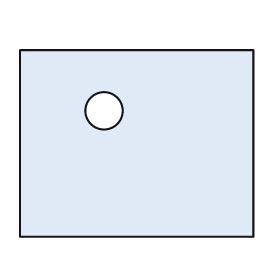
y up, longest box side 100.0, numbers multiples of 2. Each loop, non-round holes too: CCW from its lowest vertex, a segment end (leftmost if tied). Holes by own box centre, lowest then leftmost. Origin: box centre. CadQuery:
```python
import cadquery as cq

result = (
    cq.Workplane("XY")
    .moveTo(-50.0, -40.0)
    .lineTo(50.0, -40.0)
    .lineTo(50.0, 40.0)
    .lineTo(-50.0, 40.0)
    .close()
    .moveTo(-14.0, 14.0)
    .circle(8.0)
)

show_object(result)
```